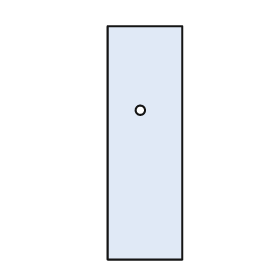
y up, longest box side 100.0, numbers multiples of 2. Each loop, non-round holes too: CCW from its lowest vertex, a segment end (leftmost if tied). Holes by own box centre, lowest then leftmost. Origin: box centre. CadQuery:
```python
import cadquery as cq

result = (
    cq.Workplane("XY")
    .moveTo(-16.0, -50.0)
    .lineTo(16.0, -50.0)
    .lineTo(16.0, 50.0)
    .lineTo(-16.0, 50.0)
    .close()
    .moveTo(-2.0, 14.0)
    .circle(2.0)
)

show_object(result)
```